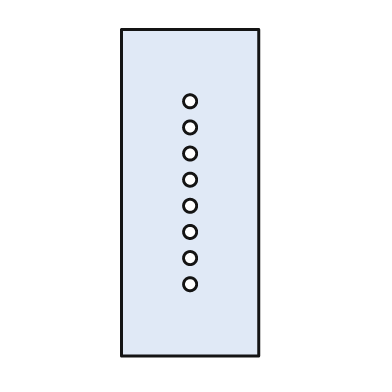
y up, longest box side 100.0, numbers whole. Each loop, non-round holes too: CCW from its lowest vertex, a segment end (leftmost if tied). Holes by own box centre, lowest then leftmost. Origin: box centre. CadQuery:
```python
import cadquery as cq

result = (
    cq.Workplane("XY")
    .moveTo(-21.0, -50.0)
    .lineTo(21.0, -50.0)
    .lineTo(21.0, 50.0)
    .lineTo(-21.0, 50.0)
    .close()
    .moveTo(0.0, -28.0)
    .circle(2.0)
    .moveTo(0.0, -20.0)
    .circle(2.0)
    .moveTo(0.0, -12.0)
    .circle(2.0)
    .moveTo(0.0, -4.0)
    .circle(2.0)
    .moveTo(0.0, 4.0)
    .circle(2.0)
    .moveTo(0.0, 12.0)
    .circle(2.0)
    .moveTo(0.0, 20.0)
    .circle(2.0)
    .moveTo(0.0, 28.0)
    .circle(2.0)
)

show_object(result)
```